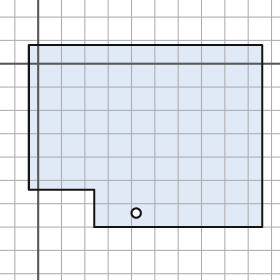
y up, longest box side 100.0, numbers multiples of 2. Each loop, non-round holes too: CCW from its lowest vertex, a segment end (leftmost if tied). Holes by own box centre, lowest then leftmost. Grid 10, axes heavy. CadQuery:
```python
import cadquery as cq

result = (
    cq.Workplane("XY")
    .moveTo(24.0, -70.0)
    .lineTo(96.0, -70.0)
    .lineTo(96.0, 8.0)
    .lineTo(-4.0, 8.0)
    .lineTo(-4.0, -54.0)
    .lineTo(24.0, -54.0)
    .close()
    .moveTo(42.0, -64.0)
    .circle(2.0)
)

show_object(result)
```